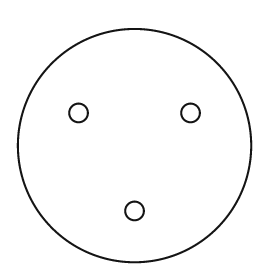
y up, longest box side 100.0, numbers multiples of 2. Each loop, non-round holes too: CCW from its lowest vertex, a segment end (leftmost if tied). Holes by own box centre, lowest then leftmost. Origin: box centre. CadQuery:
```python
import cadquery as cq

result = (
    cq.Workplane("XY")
    .moveTo(0.0, 0.0)
    .circle(50.0)
    .moveTo(0.0, -28.0)
    .circle(4.0)
    .moveTo(-24.0, 14.0)
    .circle(4.0)
    .moveTo(24.0, 14.0)
    .circle(4.0)
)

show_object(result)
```